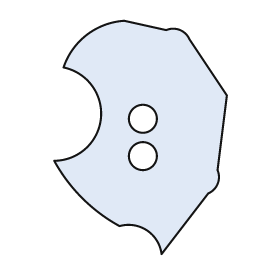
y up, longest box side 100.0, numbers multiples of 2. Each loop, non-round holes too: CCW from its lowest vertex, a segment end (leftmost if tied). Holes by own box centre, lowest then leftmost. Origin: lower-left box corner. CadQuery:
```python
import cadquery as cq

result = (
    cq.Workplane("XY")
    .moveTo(46.0, 0.0)
    .lineTo(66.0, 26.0)
    .threePointArc((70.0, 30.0), (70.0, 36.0))
    .lineTo(74.0, 68.0)
    .lineTo(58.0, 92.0)
    .threePointArc((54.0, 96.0), (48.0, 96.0))
    .lineTo(30.0, 100.0)
    .threePointArc((14.0, 94.0), (4.0, 80.0))
    .threePointArc((20.0, 58.0), (0.0, 40.0))
    .threePointArc((12.0, 24.0), (28.0, 12.0))
    .threePointArc((40.0, 10.0), (46.0, 0.0))
    .close()
    .moveTo(38.0, 42.0)
    .circle(6.0)
    .moveTo(38.0, 58.0)
    .circle(6.0)
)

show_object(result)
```